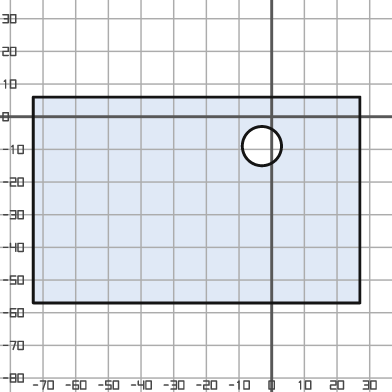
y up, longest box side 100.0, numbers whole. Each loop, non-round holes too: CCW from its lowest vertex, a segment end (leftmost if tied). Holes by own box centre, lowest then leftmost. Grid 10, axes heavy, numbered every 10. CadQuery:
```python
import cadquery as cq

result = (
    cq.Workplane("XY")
    .moveTo(-73.0, -57.0)
    .lineTo(27.0, -57.0)
    .lineTo(27.0, 6.0)
    .lineTo(-73.0, 6.0)
    .close()
    .moveTo(-3.0, -9.0)
    .circle(6.0)
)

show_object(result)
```